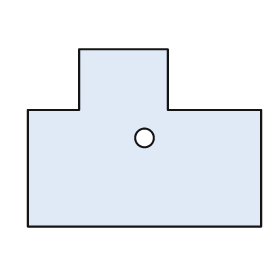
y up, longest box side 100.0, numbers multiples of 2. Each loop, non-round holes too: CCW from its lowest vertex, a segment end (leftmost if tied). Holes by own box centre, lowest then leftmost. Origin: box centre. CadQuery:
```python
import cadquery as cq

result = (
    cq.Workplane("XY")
    .moveTo(-50.0, -38.0)
    .lineTo(50.0, -38.0)
    .lineTo(50.0, 12.0)
    .lineTo(10.0, 12.0)
    .lineTo(10.0, 38.0)
    .lineTo(-28.0, 38.0)
    .lineTo(-28.0, 12.0)
    .lineTo(-50.0, 12.0)
    .close()
    .moveTo(0.0, 0.0)
    .circle(4.0)
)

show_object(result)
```